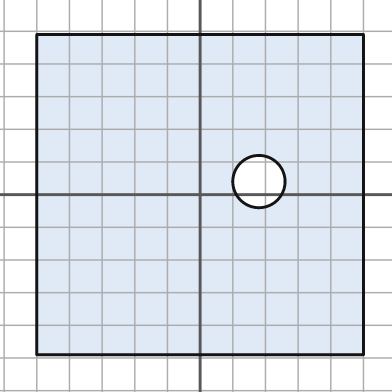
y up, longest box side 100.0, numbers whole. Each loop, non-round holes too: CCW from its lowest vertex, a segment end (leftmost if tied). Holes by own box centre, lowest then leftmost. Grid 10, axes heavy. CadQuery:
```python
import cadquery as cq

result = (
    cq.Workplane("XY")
    .moveTo(-50.0, -49.0)
    .lineTo(50.0, -49.0)
    .lineTo(50.0, 49.0)
    .lineTo(-50.0, 49.0)
    .close()
    .moveTo(18.0, 4.0)
    .circle(8.0)
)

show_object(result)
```